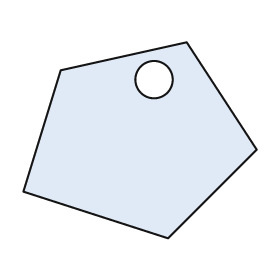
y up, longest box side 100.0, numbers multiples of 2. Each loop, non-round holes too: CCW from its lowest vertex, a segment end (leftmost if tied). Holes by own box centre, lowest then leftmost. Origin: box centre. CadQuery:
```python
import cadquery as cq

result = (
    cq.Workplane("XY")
    .moveTo(12.0, -42.0)
    .lineTo(50.0, -4.0)
    .lineTo(20.0, 42.0)
    .lineTo(-34.0, 30.0)
    .lineTo(-50.0, -22.0)
    .close()
    .moveTo(6.0, 26.0)
    .circle(8.0)
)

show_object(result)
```